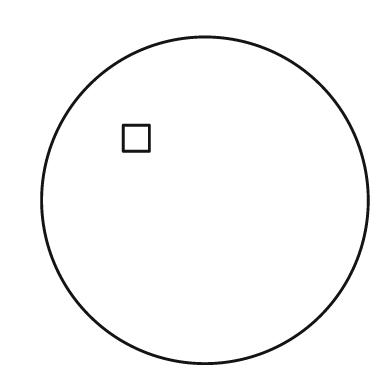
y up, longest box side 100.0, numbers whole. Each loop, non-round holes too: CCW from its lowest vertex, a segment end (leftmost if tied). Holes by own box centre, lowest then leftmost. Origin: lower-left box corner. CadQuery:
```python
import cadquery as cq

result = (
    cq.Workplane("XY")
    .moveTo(50.0, 50.0)
    .circle(50.0)
    .moveTo(25.0, 65.0)
    .lineTo(33.0, 65.0)
    .lineTo(33.0, 73.0)
    .lineTo(25.0, 73.0)
    .close()
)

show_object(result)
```